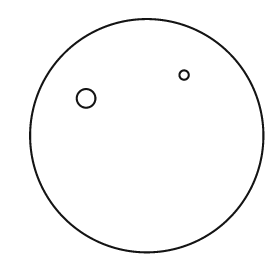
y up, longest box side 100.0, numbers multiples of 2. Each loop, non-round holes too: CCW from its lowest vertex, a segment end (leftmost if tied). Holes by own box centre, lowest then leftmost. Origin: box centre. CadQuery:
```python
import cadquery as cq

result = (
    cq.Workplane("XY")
    .moveTo(0.0, 0.0)
    .circle(50.0)
    .moveTo(-26.0, 16.0)
    .circle(4.0)
    .moveTo(16.0, 26.0)
    .circle(2.0)
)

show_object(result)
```